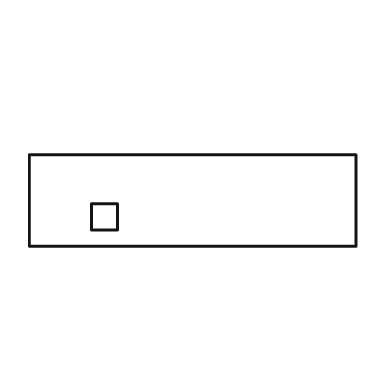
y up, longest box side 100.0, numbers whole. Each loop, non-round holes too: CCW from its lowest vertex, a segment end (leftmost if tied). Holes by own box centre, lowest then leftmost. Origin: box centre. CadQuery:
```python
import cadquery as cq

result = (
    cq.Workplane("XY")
    .moveTo(-50.0, -14.0)
    .lineTo(50.0, -14.0)
    .lineTo(50.0, 14.0)
    .lineTo(-50.0, 14.0)
    .close()
    .moveTo(-31.0, -9.0)
    .lineTo(-23.0, -9.0)
    .lineTo(-23.0, -1.0)
    .lineTo(-31.0, -1.0)
    .close()
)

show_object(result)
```